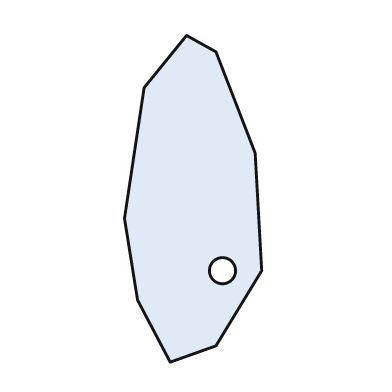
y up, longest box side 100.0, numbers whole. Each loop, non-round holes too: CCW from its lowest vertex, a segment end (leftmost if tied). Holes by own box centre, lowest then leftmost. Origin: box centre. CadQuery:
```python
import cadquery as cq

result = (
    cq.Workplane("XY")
    .moveTo(-7.0, -50.0)
    .lineTo(7.0, -45.0)
    .lineTo(21.0, -22.0)
    .lineTo(19.0, 14.0)
    .lineTo(7.0, 45.0)
    .lineTo(-2.0, 50.0)
    .lineTo(-15.0, 34.0)
    .lineTo(-21.0, -6.0)
    .lineTo(-17.0, -31.0)
    .close()
    .moveTo(9.0, -22.0)
    .circle(4.0)
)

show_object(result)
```